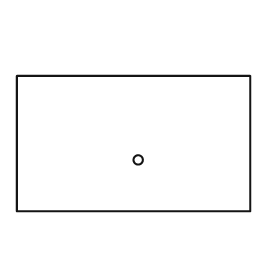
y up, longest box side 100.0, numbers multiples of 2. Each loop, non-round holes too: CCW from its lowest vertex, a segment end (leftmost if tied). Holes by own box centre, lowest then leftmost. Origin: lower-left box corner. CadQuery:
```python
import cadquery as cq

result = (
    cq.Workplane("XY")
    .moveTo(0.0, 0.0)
    .lineTo(100.0, 0.0)
    .lineTo(100.0, 58.0)
    .lineTo(0.0, 58.0)
    .close()
    .moveTo(52.0, 22.0)
    .circle(2.0)
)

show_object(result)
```